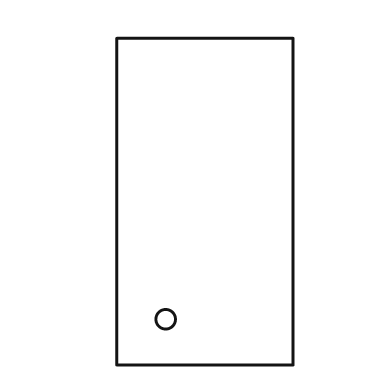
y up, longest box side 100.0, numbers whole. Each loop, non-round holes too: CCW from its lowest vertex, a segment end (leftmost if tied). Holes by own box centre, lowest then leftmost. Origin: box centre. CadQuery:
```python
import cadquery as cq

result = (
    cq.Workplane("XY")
    .moveTo(-27.0, -50.0)
    .lineTo(27.0, -50.0)
    .lineTo(27.0, 50.0)
    .lineTo(-27.0, 50.0)
    .close()
    .moveTo(-12.0, -36.0)
    .circle(3.0)
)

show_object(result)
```